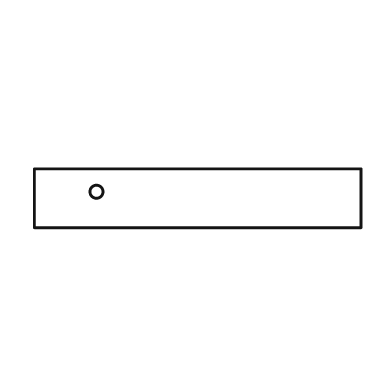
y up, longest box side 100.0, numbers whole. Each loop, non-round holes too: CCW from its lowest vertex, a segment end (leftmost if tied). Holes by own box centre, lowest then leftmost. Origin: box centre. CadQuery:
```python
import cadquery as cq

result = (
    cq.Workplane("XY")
    .moveTo(-50.0, -9.0)
    .lineTo(50.0, -9.0)
    .lineTo(50.0, 9.0)
    .lineTo(-50.0, 9.0)
    .close()
    .moveTo(-31.0, 2.0)
    .circle(2.0)
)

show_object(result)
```